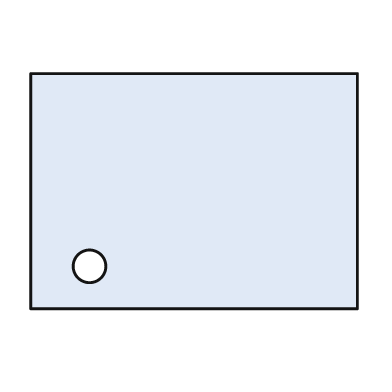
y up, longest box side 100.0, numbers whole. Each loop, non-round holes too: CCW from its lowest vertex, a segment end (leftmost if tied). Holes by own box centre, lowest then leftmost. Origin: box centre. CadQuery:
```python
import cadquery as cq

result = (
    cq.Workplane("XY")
    .moveTo(-50.0, -36.0)
    .lineTo(50.0, -36.0)
    .lineTo(50.0, 36.0)
    .lineTo(-50.0, 36.0)
    .close()
    .moveTo(-32.0, -23.0)
    .circle(5.0)
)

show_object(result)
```